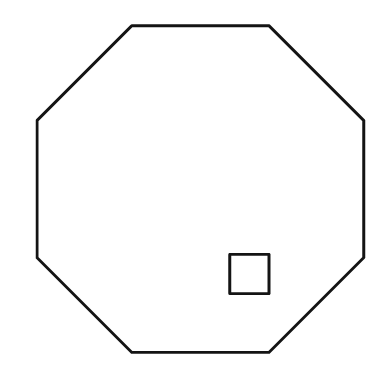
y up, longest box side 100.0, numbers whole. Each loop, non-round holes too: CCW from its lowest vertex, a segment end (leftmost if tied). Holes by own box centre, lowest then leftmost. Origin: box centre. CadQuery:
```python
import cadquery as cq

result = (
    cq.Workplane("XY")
    .moveTo(-21.0, -50.0)
    .lineTo(21.0, -50.0)
    .lineTo(50.0, -21.0)
    .lineTo(50.0, 21.0)
    .lineTo(21.0, 50.0)
    .lineTo(-21.0, 50.0)
    .lineTo(-50.0, 21.0)
    .lineTo(-50.0, -21.0)
    .close()
    .moveTo(9.0, -32.0)
    .lineTo(21.0, -32.0)
    .lineTo(21.0, -20.0)
    .lineTo(9.0, -20.0)
    .close()
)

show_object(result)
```